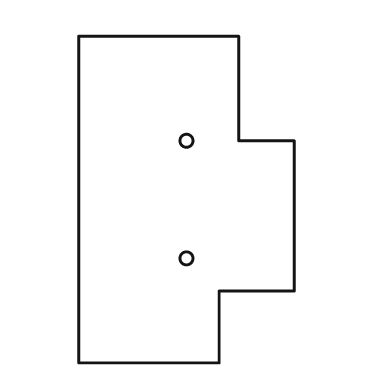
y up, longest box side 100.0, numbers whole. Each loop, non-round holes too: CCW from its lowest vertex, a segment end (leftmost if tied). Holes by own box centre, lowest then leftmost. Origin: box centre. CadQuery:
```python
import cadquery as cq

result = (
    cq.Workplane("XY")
    .moveTo(-33.0, -50.0)
    .lineTo(10.0, -50.0)
    .lineTo(10.0, -28.0)
    .lineTo(33.0, -28.0)
    .lineTo(33.0, 18.0)
    .lineTo(16.0, 18.0)
    .lineTo(16.0, 50.0)
    .lineTo(-33.0, 50.0)
    .close()
    .moveTo(0.0, -18.0)
    .circle(2.0)
    .moveTo(0.0, 18.0)
    .circle(2.0)
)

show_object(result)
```